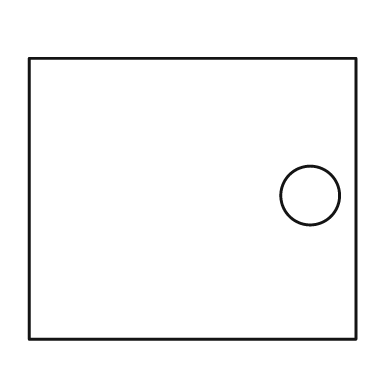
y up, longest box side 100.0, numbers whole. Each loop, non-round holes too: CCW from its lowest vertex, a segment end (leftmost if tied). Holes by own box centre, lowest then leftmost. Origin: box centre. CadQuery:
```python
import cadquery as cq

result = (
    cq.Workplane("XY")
    .moveTo(-50.0, -43.0)
    .lineTo(50.0, -43.0)
    .lineTo(50.0, 43.0)
    .lineTo(-50.0, 43.0)
    .close()
    .moveTo(36.0, 1.0)
    .circle(9.0)
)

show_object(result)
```